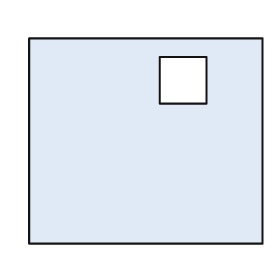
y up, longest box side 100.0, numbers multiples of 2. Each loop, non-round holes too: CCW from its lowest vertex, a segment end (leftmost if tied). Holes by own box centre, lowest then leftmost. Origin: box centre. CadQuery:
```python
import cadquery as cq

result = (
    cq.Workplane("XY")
    .moveTo(-50.0, -44.0)
    .lineTo(50.0, -44.0)
    .lineTo(50.0, 44.0)
    .lineTo(-50.0, 44.0)
    .close()
    .moveTo(6.0, 16.0)
    .lineTo(26.0, 16.0)
    .lineTo(26.0, 36.0)
    .lineTo(6.0, 36.0)
    .close()
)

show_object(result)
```